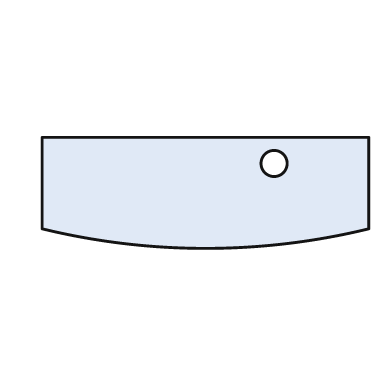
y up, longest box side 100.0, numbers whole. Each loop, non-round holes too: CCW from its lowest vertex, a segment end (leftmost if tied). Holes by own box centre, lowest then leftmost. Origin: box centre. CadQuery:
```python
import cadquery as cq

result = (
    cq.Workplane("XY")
    .moveTo(-50.0, -11.0)
    .threePointArc((0.0, -17.0), (50.0, -11.0))
    .lineTo(50.0, 17.0)
    .lineTo(-50.0, 17.0)
    .close()
    .moveTo(21.0, 9.0)
    .circle(4.0)
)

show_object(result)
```